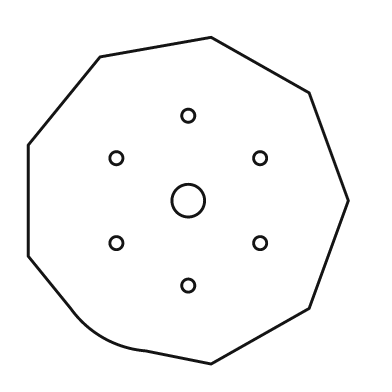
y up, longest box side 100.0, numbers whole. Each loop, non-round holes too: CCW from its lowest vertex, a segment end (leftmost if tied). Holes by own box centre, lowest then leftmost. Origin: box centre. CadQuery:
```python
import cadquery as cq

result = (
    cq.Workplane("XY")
    .moveTo(7.0, -50.0)
    .lineTo(37.0, -33.0)
    .lineTo(49.0, 0.0)
    .lineTo(37.0, 33.0)
    .lineTo(7.0, 50.0)
    .lineTo(-27.0, 44.0)
    .lineTo(-49.0, 17.0)
    .lineTo(-49.0, -17.0)
    .lineTo(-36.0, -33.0)
    .threePointArc((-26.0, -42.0), (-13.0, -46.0))
    .close()
    .moveTo(0.0, -26.0)
    .circle(2.0)
    .moveTo(-22.0, -13.0)
    .circle(2.0)
    .moveTo(22.0, -13.0)
    .circle(2.0)
    .moveTo(0.0, 0.0)
    .circle(5.0)
    .moveTo(-22.0, 13.0)
    .circle(2.0)
    .moveTo(22.0, 13.0)
    .circle(2.0)
    .moveTo(0.0, 26.0)
    .circle(2.0)
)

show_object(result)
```